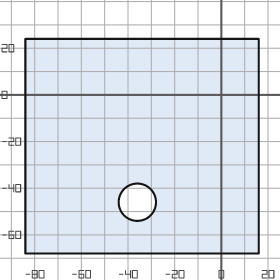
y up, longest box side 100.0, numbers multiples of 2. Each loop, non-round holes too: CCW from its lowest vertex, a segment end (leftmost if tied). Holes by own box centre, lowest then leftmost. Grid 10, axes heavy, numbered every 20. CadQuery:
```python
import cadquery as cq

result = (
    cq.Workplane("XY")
    .moveTo(-84.0, -68.0)
    .lineTo(16.0, -68.0)
    .lineTo(16.0, 24.0)
    .lineTo(-84.0, 24.0)
    .close()
    .moveTo(-36.0, -46.0)
    .circle(8.0)
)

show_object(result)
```